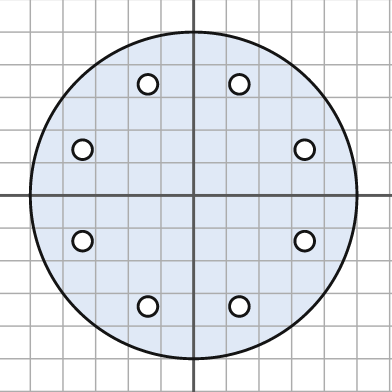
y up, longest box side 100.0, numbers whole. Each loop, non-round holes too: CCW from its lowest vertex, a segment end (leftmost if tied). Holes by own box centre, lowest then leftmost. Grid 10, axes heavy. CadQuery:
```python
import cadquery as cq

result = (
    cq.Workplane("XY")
    .moveTo(0.0, 0.0)
    .circle(50.0)
    .moveTo(-14.0, -34.0)
    .circle(3.0)
    .moveTo(14.0, -34.0)
    .circle(3.0)
    .moveTo(-34.0, -14.0)
    .circle(3.0)
    .moveTo(34.0, -14.0)
    .circle(3.0)
    .moveTo(-34.0, 14.0)
    .circle(3.0)
    .moveTo(34.0, 14.0)
    .circle(3.0)
    .moveTo(-14.0, 34.0)
    .circle(3.0)
    .moveTo(14.0, 34.0)
    .circle(3.0)
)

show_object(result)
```